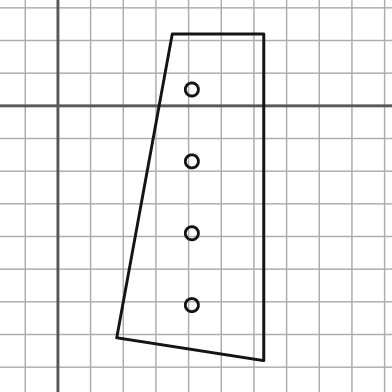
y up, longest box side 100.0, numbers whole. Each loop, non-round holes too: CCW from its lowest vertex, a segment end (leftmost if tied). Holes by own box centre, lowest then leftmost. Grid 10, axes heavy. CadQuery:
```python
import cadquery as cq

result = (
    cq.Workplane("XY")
    .moveTo(63.0, -78.0)
    .lineTo(63.0, 22.0)
    .lineTo(35.0, 22.0)
    .lineTo(18.0, -71.0)
    .close()
    .moveTo(41.0, -61.0)
    .circle(2.0)
    .moveTo(41.0, -39.0)
    .circle(2.0)
    .moveTo(41.0, -17.0)
    .circle(2.0)
    .moveTo(41.0, 5.0)
    .circle(2.0)
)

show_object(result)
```